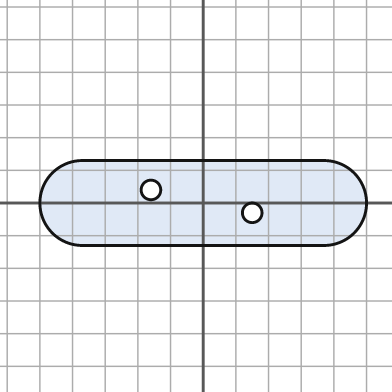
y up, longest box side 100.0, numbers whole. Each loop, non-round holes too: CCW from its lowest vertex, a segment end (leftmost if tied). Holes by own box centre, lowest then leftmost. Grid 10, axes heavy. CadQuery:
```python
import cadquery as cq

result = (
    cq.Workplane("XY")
    .moveTo(-37.0, -13.0)
    .lineTo(37.0, -13.0)
    .threePointArc((50.0, 0.0), (37.0, 13.0))
    .lineTo(-37.0, 13.0)
    .threePointArc((-50.0, 0.0), (-37.0, -13.0))
    .close()
    .moveTo(15.0, -3.0)
    .circle(3.0)
    .moveTo(-16.0, 4.0)
    .circle(3.0)
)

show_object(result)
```